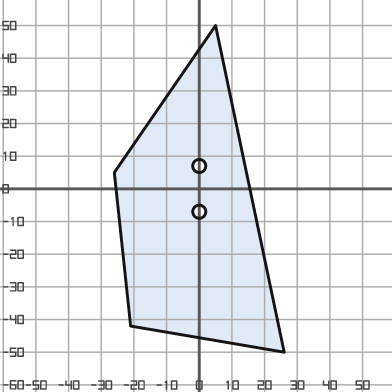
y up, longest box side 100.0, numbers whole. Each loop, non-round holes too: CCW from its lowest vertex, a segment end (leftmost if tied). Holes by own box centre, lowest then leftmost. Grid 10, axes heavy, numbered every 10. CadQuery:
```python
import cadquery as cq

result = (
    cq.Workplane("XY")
    .moveTo(26.0, -50.0)
    .lineTo(5.0, 50.0)
    .lineTo(-26.0, 5.0)
    .lineTo(-21.0, -42.0)
    .close()
    .moveTo(0.0, -7.0)
    .circle(2.0)
    .moveTo(0.0, 7.0)
    .circle(2.0)
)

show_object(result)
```